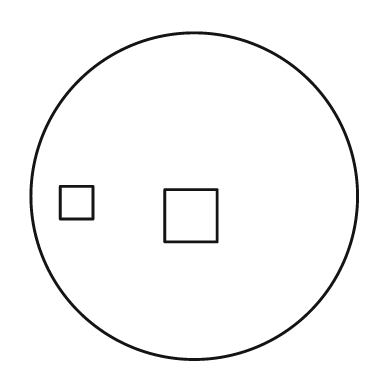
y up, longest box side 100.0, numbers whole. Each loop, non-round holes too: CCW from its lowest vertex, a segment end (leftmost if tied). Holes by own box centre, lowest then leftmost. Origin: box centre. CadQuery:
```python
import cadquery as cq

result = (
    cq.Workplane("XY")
    .moveTo(0.0, 0.0)
    .circle(50.0)
    .moveTo(-9.0, -14.0)
    .lineTo(7.0, -14.0)
    .lineTo(7.0, 2.0)
    .lineTo(-9.0, 2.0)
    .close()
    .moveTo(-41.0, -7.0)
    .lineTo(-31.0, -7.0)
    .lineTo(-31.0, 3.0)
    .lineTo(-41.0, 3.0)
    .close()
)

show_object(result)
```